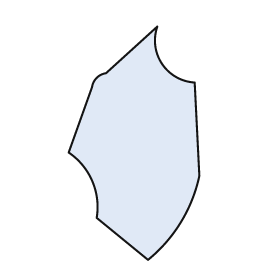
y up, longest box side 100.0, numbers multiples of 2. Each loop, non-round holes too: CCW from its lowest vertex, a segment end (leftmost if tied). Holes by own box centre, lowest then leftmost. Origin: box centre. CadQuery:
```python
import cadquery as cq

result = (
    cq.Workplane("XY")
    .moveTo(6.0, -50.0)
    .threePointArc((20.0, -34.0), (28.0, -14.0))
    .lineTo(26.0, 26.0)
    .threePointArc((12.0, 34.0), (10.0, 50.0))
    .lineTo(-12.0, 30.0)
    .threePointArc((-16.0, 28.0), (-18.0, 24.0))
    .lineTo(-28.0, -4.0)
    .threePointArc((-18.0, -16.0), (-16.0, -32.0))
    .close()
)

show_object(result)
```